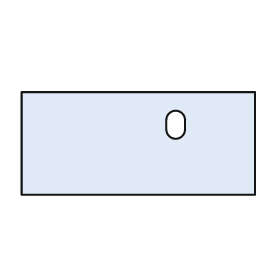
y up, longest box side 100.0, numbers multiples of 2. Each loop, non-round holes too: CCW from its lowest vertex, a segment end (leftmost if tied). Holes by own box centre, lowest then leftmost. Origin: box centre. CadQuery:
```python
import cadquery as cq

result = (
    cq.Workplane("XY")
    .moveTo(-50.0, -22.0)
    .lineTo(50.0, -22.0)
    .lineTo(50.0, 22.0)
    .lineTo(-50.0, 22.0)
    .close()
    .moveTo(12.0, 6.0)
    .threePointArc((16.0, 2.0), (20.0, 6.0))
    .lineTo(20.0, 10.0)
    .threePointArc((16.0, 14.0), (12.0, 10.0))
    .close()
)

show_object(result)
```